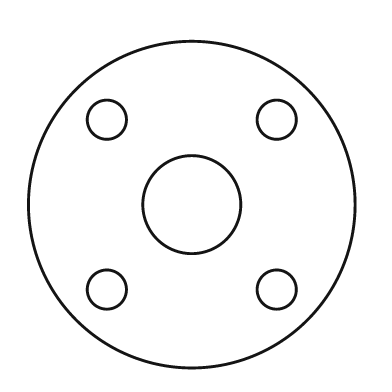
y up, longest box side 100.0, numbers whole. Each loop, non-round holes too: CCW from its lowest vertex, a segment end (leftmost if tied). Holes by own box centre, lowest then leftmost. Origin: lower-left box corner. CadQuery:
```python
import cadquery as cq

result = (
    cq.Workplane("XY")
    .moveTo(50.0, 50.0)
    .circle(50.0)
    .moveTo(24.0, 24.0)
    .circle(6.0)
    .moveTo(76.0, 24.0)
    .circle(6.0)
    .moveTo(50.0, 50.0)
    .circle(15.0)
    .moveTo(24.0, 76.0)
    .circle(6.0)
    .moveTo(76.0, 76.0)
    .circle(6.0)
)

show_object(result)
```